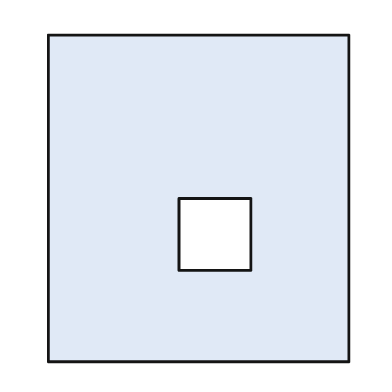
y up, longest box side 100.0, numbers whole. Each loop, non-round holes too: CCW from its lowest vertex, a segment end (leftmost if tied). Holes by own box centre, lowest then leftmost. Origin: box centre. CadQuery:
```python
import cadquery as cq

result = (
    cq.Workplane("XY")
    .moveTo(-46.0, -50.0)
    .lineTo(46.0, -50.0)
    .lineTo(46.0, 50.0)
    .lineTo(-46.0, 50.0)
    .close()
    .moveTo(-6.0, -22.0)
    .lineTo(16.0, -22.0)
    .lineTo(16.0, 0.0)
    .lineTo(-6.0, 0.0)
    .close()
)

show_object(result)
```